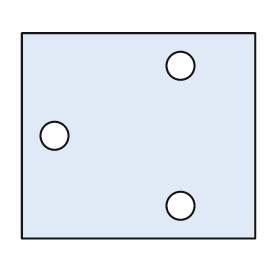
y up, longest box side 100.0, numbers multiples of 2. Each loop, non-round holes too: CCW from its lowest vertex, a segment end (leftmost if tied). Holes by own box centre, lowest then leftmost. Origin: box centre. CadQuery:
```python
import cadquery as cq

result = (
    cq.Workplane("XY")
    .moveTo(-50.0, -44.0)
    .lineTo(50.0, -44.0)
    .lineTo(50.0, 44.0)
    .lineTo(-50.0, 44.0)
    .close()
    .moveTo(18.0, -30.0)
    .circle(6.0)
    .moveTo(-36.0, 0.0)
    .circle(6.0)
    .moveTo(18.0, 30.0)
    .circle(6.0)
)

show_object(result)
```